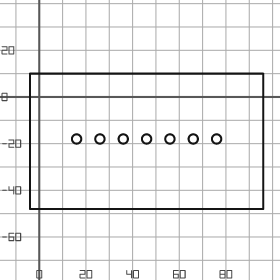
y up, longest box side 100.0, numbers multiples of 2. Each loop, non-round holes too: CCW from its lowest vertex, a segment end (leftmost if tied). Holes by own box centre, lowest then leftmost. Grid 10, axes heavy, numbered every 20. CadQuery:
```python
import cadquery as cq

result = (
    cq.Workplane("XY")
    .moveTo(-4.0, -48.0)
    .lineTo(96.0, -48.0)
    .lineTo(96.0, 10.0)
    .lineTo(-4.0, 10.0)
    .close()
    .moveTo(16.0, -18.0)
    .circle(2.0)
    .moveTo(26.0, -18.0)
    .circle(2.0)
    .moveTo(36.0, -18.0)
    .circle(2.0)
    .moveTo(46.0, -18.0)
    .circle(2.0)
    .moveTo(56.0, -18.0)
    .circle(2.0)
    .moveTo(66.0, -18.0)
    .circle(2.0)
    .moveTo(76.0, -18.0)
    .circle(2.0)
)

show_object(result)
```